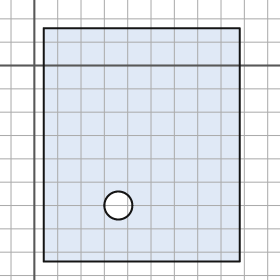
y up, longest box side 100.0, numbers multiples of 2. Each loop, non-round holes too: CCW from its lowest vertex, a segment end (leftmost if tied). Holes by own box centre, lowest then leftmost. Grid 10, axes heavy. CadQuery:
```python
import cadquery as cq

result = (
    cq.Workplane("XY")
    .moveTo(4.0, -84.0)
    .lineTo(88.0, -84.0)
    .lineTo(88.0, 16.0)
    .lineTo(4.0, 16.0)
    .close()
    .moveTo(36.0, -60.0)
    .circle(6.0)
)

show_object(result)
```